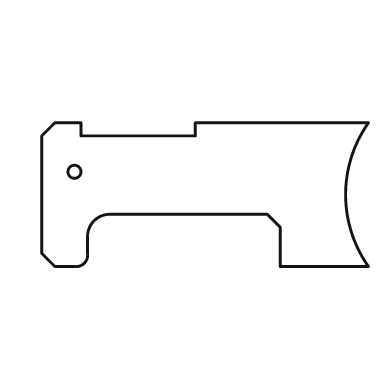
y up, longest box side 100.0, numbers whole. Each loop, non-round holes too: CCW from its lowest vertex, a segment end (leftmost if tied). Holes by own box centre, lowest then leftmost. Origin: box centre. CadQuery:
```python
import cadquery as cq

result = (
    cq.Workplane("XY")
    .moveTo(-46.0, -22.0)
    .lineTo(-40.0, -22.0)
    .threePointArc((-37.0, -21.0), (-36.0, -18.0))
    .lineTo(-36.0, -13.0)
    .threePointArc((-34.0, -8.0), (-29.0, -6.0))
    .lineTo(19.0, -6.0)
    .lineTo(23.0, -10.0)
    .lineTo(23.0, -22.0)
    .lineTo(50.0, -22.0)
    .threePointArc((43.0, 0.0), (50.0, 22.0))
    .lineTo(-3.0, 22.0)
    .lineTo(-3.0, 18.0)
    .lineTo(-38.0, 18.0)
    .lineTo(-38.0, 22.0)
    .lineTo(-46.0, 22.0)
    .lineTo(-50.0, 18.0)
    .lineTo(-50.0, -18.0)
    .close()
    .moveTo(-40.0, 7.0)
    .circle(2.0)
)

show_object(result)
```